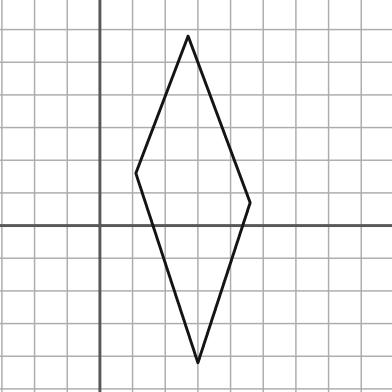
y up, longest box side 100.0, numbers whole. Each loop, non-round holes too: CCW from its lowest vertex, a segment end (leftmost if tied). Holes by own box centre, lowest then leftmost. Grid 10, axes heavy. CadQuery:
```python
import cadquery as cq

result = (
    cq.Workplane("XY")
    .moveTo(30.0, -42.0)
    .lineTo(46.0, 7.0)
    .lineTo(27.0, 58.0)
    .lineTo(11.0, 16.0)
    .close()
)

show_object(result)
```